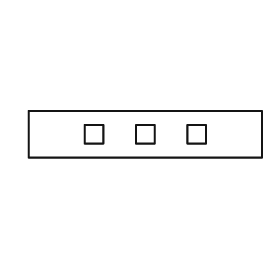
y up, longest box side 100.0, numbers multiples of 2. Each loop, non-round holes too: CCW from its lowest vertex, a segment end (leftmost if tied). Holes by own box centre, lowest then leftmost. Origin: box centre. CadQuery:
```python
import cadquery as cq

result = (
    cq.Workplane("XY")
    .moveTo(-50.0, -10.0)
    .lineTo(50.0, -10.0)
    .lineTo(50.0, 10.0)
    .lineTo(-50.0, 10.0)
    .close()
    .moveTo(-26.0, -4.0)
    .lineTo(-18.0, -4.0)
    .lineTo(-18.0, 4.0)
    .lineTo(-26.0, 4.0)
    .close()
    .moveTo(-4.0, -4.0)
    .lineTo(4.0, -4.0)
    .lineTo(4.0, 4.0)
    .lineTo(-4.0, 4.0)
    .close()
    .moveTo(18.0, -4.0)
    .lineTo(26.0, -4.0)
    .lineTo(26.0, 4.0)
    .lineTo(18.0, 4.0)
    .close()
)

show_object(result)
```